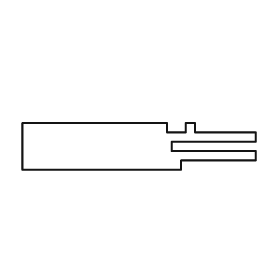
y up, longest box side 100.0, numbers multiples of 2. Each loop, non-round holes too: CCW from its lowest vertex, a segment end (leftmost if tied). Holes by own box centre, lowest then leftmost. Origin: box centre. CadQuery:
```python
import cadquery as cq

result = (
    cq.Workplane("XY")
    .moveTo(-50.0, -10.0)
    .lineTo(18.0, -10.0)
    .lineTo(18.0, -6.0)
    .lineTo(50.0, -6.0)
    .lineTo(50.0, -2.0)
    .lineTo(14.0, -2.0)
    .lineTo(14.0, 2.0)
    .lineTo(50.0, 2.0)
    .lineTo(50.0, 6.0)
    .lineTo(24.0, 6.0)
    .lineTo(24.0, 10.0)
    .lineTo(20.0, 10.0)
    .lineTo(20.0, 6.0)
    .lineTo(12.0, 6.0)
    .lineTo(12.0, 10.0)
    .lineTo(-50.0, 10.0)
    .close()
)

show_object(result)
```